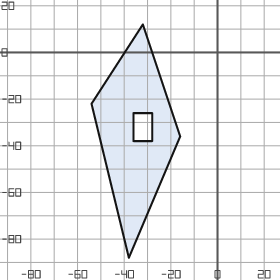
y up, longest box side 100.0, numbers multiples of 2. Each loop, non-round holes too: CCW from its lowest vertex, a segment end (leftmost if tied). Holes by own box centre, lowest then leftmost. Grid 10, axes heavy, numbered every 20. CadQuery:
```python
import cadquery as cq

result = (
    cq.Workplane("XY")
    .moveTo(-38.0, -88.0)
    .lineTo(-16.0, -36.0)
    .lineTo(-32.0, 12.0)
    .lineTo(-54.0, -22.0)
    .close()
    .moveTo(-36.0, -38.0)
    .lineTo(-28.0, -38.0)
    .lineTo(-28.0, -26.0)
    .lineTo(-36.0, -26.0)
    .close()
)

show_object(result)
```